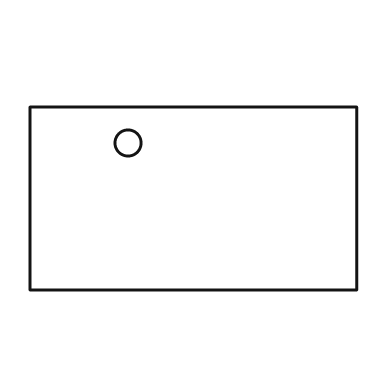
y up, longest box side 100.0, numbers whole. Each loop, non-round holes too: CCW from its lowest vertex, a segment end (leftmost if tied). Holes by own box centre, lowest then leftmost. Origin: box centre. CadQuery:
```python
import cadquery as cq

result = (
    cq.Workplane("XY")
    .moveTo(-50.0, -28.0)
    .lineTo(50.0, -28.0)
    .lineTo(50.0, 28.0)
    .lineTo(-50.0, 28.0)
    .close()
    .moveTo(-20.0, 17.0)
    .circle(4.0)
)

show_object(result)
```